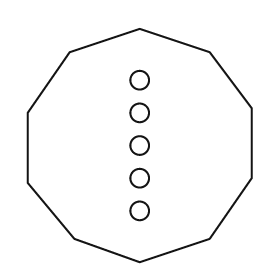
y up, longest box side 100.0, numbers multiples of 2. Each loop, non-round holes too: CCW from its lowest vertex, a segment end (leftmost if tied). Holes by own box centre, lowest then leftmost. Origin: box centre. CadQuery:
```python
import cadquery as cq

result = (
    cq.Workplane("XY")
    .moveTo(0.0, -50.0)
    .lineTo(30.0, -40.0)
    .lineTo(48.0, -14.0)
    .lineTo(48.0, 16.0)
    .lineTo(30.0, 40.0)
    .lineTo(0.0, 50.0)
    .lineTo(-30.0, 40.0)
    .lineTo(-48.0, 14.0)
    .lineTo(-48.0, -16.0)
    .lineTo(-28.0, -40.0)
    .close()
    .moveTo(0.0, -28.0)
    .circle(4.0)
    .moveTo(0.0, -14.0)
    .circle(4.0)
    .moveTo(0.0, 0.0)
    .circle(4.0)
    .moveTo(0.0, 14.0)
    .circle(4.0)
    .moveTo(0.0, 28.0)
    .circle(4.0)
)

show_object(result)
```